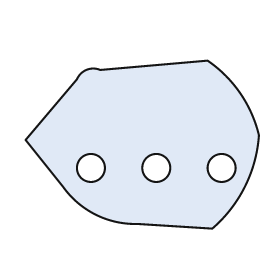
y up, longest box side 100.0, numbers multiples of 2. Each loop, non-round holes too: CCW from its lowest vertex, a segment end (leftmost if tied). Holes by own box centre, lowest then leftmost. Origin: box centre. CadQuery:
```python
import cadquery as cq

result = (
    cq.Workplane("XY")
    .moveTo(30.0, -36.0)
    .threePointArc((44.0, -18.0), (50.0, 4.0))
    .threePointArc((42.0, 22.0), (28.0, 36.0))
    .lineTo(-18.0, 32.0)
    .threePointArc((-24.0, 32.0), (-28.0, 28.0))
    .lineTo(-50.0, 2.0)
    .lineTo(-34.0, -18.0)
    .threePointArc((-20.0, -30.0), (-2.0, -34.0))
    .close()
    .moveTo(-22.0, -10.0)
    .circle(6.0)
    .moveTo(6.0, -10.0)
    .circle(6.0)
    .moveTo(34.0, -10.0)
    .circle(6.0)
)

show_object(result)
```